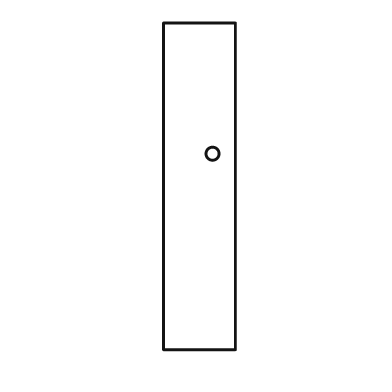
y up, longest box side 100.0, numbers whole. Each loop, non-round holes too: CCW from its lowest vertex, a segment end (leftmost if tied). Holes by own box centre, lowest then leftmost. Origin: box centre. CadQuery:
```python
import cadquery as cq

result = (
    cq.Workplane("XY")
    .moveTo(-11.0, -50.0)
    .lineTo(11.0, -50.0)
    .lineTo(11.0, 50.0)
    .lineTo(-11.0, 50.0)
    .close()
    .moveTo(4.0, 10.0)
    .circle(2.0)
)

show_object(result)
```